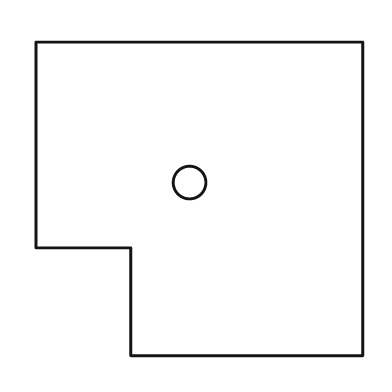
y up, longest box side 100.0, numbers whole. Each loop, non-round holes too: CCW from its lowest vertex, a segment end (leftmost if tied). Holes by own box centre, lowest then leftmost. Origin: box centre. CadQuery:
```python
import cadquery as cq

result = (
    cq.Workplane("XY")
    .moveTo(-21.0, -48.0)
    .lineTo(50.0, -48.0)
    .lineTo(50.0, 48.0)
    .lineTo(-50.0, 48.0)
    .lineTo(-50.0, -15.0)
    .lineTo(-21.0, -15.0)
    .close()
    .moveTo(-3.0, 5.0)
    .circle(5.0)
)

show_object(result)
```